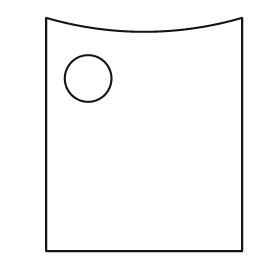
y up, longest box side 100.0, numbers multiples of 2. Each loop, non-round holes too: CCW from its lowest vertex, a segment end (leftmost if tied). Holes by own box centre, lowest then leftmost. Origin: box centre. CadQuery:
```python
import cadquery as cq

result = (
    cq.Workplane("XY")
    .moveTo(-42.0, -50.0)
    .lineTo(42.0, -50.0)
    .lineTo(42.0, 50.0)
    .threePointArc((0.0, 44.0), (-42.0, 50.0))
    .close()
    .moveTo(-24.0, 24.0)
    .circle(10.0)
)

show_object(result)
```